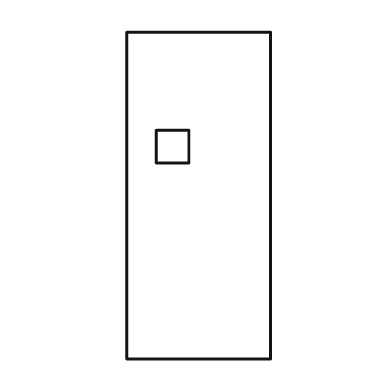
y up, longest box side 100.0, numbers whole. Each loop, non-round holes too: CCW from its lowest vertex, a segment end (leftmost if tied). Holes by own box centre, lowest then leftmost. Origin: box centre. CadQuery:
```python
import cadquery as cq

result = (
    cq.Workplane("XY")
    .moveTo(-22.0, -50.0)
    .lineTo(22.0, -50.0)
    .lineTo(22.0, 50.0)
    .lineTo(-22.0, 50.0)
    .close()
    .moveTo(-13.0, 10.0)
    .lineTo(-3.0, 10.0)
    .lineTo(-3.0, 20.0)
    .lineTo(-13.0, 20.0)
    .close()
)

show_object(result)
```